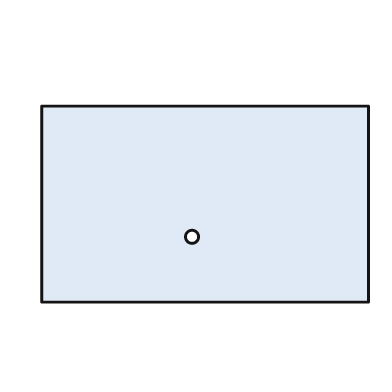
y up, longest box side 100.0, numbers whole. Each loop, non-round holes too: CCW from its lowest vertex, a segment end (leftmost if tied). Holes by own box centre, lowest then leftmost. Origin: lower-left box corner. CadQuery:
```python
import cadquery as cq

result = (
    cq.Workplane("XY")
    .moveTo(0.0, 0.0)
    .lineTo(100.0, 0.0)
    .lineTo(100.0, 60.0)
    .lineTo(0.0, 60.0)
    .close()
    .moveTo(46.0, 20.0)
    .circle(2.0)
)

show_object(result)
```